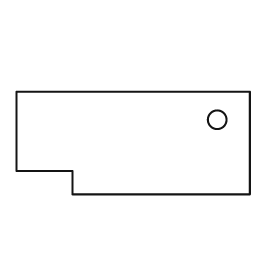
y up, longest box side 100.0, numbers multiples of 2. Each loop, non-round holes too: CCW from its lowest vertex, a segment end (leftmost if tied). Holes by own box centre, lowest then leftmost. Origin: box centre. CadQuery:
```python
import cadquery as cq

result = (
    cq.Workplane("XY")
    .moveTo(-26.0, -22.0)
    .lineTo(50.0, -22.0)
    .lineTo(50.0, 22.0)
    .lineTo(-50.0, 22.0)
    .lineTo(-50.0, -12.0)
    .lineTo(-26.0, -12.0)
    .close()
    .moveTo(36.0, 10.0)
    .circle(4.0)
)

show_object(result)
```